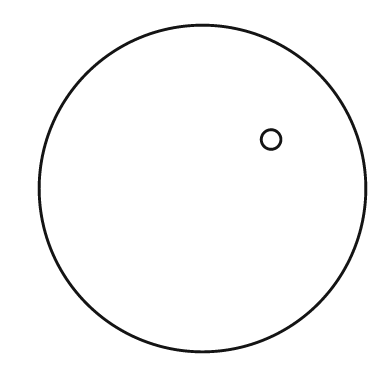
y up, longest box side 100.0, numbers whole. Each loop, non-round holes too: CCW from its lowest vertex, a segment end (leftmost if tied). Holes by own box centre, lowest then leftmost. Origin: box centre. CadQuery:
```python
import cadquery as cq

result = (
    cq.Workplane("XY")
    .moveTo(0.0, 0.0)
    .circle(50.0)
    .moveTo(21.0, 15.0)
    .circle(3.0)
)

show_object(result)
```